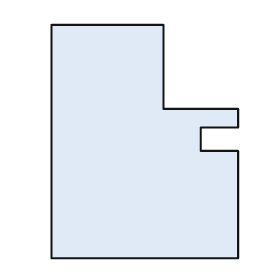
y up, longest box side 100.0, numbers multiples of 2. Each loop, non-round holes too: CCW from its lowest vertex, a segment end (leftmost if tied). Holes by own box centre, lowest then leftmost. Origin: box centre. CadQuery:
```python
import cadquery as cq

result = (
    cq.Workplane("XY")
    .moveTo(-40.0, -50.0)
    .lineTo(40.0, -50.0)
    .lineTo(40.0, -4.0)
    .lineTo(24.0, -4.0)
    .lineTo(24.0, 6.0)
    .lineTo(40.0, 6.0)
    .lineTo(40.0, 14.0)
    .lineTo(8.0, 14.0)
    .lineTo(8.0, 50.0)
    .lineTo(-40.0, 50.0)
    .close()
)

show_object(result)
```